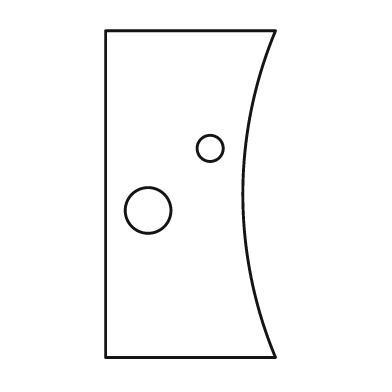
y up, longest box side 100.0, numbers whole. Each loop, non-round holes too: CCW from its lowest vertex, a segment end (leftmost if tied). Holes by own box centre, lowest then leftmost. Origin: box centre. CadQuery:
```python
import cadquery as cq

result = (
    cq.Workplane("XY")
    .moveTo(-26.0, -50.0)
    .lineTo(26.0, -50.0)
    .threePointArc((16.0, 0.0), (26.0, 50.0))
    .lineTo(-26.0, 50.0)
    .close()
    .moveTo(-13.0, -5.0)
    .circle(7.0)
    .moveTo(6.0, 14.0)
    .circle(4.0)
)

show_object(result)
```